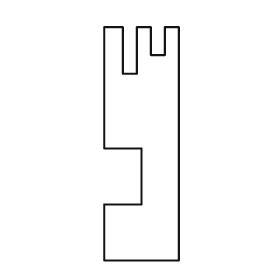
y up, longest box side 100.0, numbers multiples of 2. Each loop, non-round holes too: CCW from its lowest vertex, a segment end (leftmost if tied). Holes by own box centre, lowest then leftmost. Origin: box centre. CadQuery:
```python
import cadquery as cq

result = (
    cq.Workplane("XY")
    .moveTo(-16.0, -50.0)
    .lineTo(16.0, -50.0)
    .lineTo(16.0, 50.0)
    .lineTo(10.0, 50.0)
    .lineTo(10.0, 38.0)
    .lineTo(4.0, 38.0)
    .lineTo(4.0, 50.0)
    .lineTo(-2.0, 50.0)
    .lineTo(-2.0, 30.0)
    .lineTo(-8.0, 30.0)
    .lineTo(-8.0, 50.0)
    .lineTo(-16.0, 50.0)
    .lineTo(-16.0, -2.0)
    .lineTo(0.0, -2.0)
    .lineTo(0.0, -26.0)
    .lineTo(-16.0, -26.0)
    .close()
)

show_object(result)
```